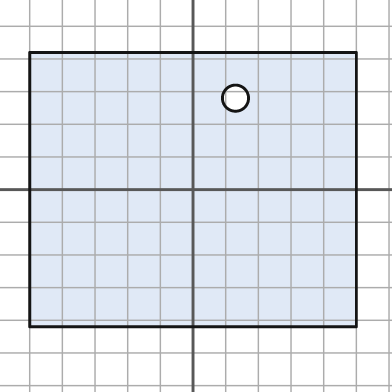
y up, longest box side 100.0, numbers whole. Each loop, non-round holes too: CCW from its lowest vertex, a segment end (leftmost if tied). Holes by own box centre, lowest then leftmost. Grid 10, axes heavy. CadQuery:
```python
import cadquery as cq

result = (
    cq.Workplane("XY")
    .moveTo(-50.0, -42.0)
    .lineTo(50.0, -42.0)
    .lineTo(50.0, 42.0)
    .lineTo(-50.0, 42.0)
    .close()
    .moveTo(13.0, 28.0)
    .circle(4.0)
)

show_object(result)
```